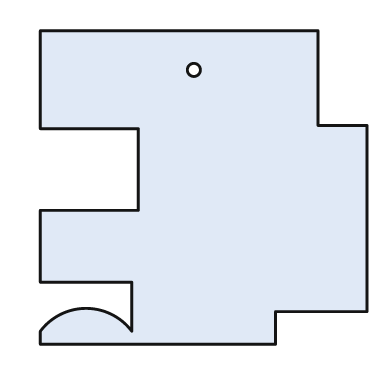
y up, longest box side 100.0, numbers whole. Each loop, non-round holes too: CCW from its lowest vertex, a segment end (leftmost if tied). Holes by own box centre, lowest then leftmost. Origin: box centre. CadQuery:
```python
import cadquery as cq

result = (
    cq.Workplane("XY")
    .moveTo(-50.0, -48.0)
    .lineTo(22.0, -48.0)
    .lineTo(22.0, -38.0)
    .lineTo(50.0, -38.0)
    .lineTo(50.0, 19.0)
    .lineTo(35.0, 19.0)
    .lineTo(35.0, 48.0)
    .lineTo(-50.0, 48.0)
    .lineTo(-50.0, 18.0)
    .lineTo(-20.0, 18.0)
    .lineTo(-20.0, -7.0)
    .lineTo(-50.0, -7.0)
    .lineTo(-50.0, -29.0)
    .lineTo(-22.0, -29.0)
    .lineTo(-22.0, -44.0)
    .threePointArc((-36.0, -37.0), (-50.0, -44.0))
    .close()
    .moveTo(-3.0, 36.0)
    .circle(2.0)
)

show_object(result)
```